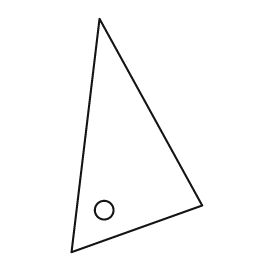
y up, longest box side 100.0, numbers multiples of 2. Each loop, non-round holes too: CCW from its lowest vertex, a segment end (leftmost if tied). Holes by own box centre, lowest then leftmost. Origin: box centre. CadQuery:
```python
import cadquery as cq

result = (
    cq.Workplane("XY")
    .moveTo(-28.0, -50.0)
    .lineTo(28.0, -30.0)
    .lineTo(-16.0, 50.0)
    .close()
    .moveTo(-14.0, -32.0)
    .circle(4.0)
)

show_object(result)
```